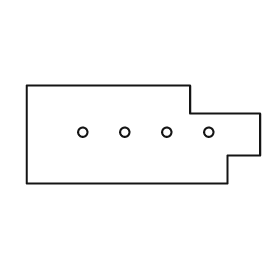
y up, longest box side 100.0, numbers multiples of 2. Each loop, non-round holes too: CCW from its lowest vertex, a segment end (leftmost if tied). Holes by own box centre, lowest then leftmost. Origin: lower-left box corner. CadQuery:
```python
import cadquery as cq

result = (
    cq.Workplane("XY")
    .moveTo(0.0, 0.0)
    .lineTo(86.0, 0.0)
    .lineTo(86.0, 12.0)
    .lineTo(100.0, 12.0)
    .lineTo(100.0, 30.0)
    .lineTo(70.0, 30.0)
    .lineTo(70.0, 42.0)
    .lineTo(0.0, 42.0)
    .close()
    .moveTo(24.0, 22.0)
    .circle(2.0)
    .moveTo(42.0, 22.0)
    .circle(2.0)
    .moveTo(60.0, 22.0)
    .circle(2.0)
    .moveTo(78.0, 22.0)
    .circle(2.0)
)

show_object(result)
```